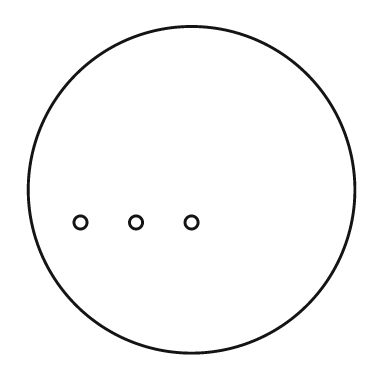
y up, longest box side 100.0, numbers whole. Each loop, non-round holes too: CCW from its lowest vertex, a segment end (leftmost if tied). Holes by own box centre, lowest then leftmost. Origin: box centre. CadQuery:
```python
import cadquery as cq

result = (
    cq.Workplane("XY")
    .moveTo(0.0, 0.0)
    .circle(50.0)
    .moveTo(-34.0, -10.0)
    .circle(2.0)
    .moveTo(-17.0, -10.0)
    .circle(2.0)
    .moveTo(0.0, -10.0)
    .circle(2.0)
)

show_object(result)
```